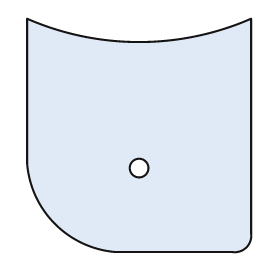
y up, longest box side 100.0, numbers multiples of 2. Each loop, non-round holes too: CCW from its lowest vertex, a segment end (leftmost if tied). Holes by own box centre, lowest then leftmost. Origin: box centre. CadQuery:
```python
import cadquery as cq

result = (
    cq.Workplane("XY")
    .moveTo(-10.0, -50.0)
    .lineTo(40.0, -50.0)
    .threePointArc((46.0, -48.0), (48.0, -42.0))
    .lineTo(48.0, 50.0)
    .threePointArc((0.0, 40.0), (-48.0, 50.0))
    .lineTo(-48.0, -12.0)
    .threePointArc((-36.0, -38.0), (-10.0, -50.0))
    .close()
    .moveTo(0.0, -14.0)
    .circle(4.0)
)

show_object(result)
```